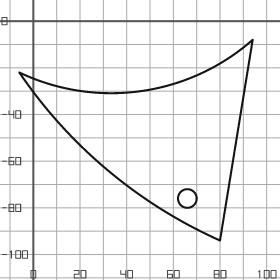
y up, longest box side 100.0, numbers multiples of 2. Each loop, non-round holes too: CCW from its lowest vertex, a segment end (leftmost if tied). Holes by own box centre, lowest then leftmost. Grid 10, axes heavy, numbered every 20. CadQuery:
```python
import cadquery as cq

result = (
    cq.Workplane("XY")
    .moveTo(80.0, -94.0)
    .lineTo(94.0, -8.0)
    .threePointArc((46.0, -30.0), (-6.0, -22.0))
    .threePointArc((32.0, -64.0), (80.0, -94.0))
    .close()
    .moveTo(66.0, -76.0)
    .circle(4.0)
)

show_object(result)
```